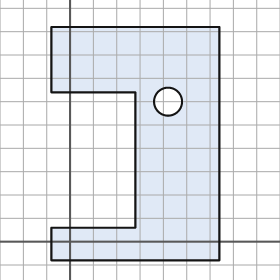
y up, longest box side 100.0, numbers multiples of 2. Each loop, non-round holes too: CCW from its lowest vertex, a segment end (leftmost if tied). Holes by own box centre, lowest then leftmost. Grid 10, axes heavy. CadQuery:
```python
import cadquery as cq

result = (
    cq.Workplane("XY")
    .moveTo(-8.0, -8.0)
    .lineTo(64.0, -8.0)
    .lineTo(64.0, 92.0)
    .lineTo(-8.0, 92.0)
    .lineTo(-8.0, 64.0)
    .lineTo(28.0, 64.0)
    .lineTo(28.0, 6.0)
    .lineTo(-8.0, 6.0)
    .close()
    .moveTo(42.0, 60.0)
    .circle(6.0)
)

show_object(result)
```